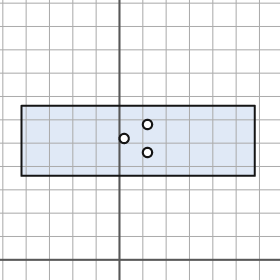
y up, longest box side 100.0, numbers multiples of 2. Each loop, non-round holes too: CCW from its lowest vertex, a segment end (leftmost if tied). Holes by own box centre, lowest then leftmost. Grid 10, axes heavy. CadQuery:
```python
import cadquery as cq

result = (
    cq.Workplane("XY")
    .moveTo(-42.0, 36.0)
    .lineTo(58.0, 36.0)
    .lineTo(58.0, 66.0)
    .lineTo(-42.0, 66.0)
    .close()
    .moveTo(12.0, 46.0)
    .circle(2.0)
    .moveTo(2.0, 52.0)
    .circle(2.0)
    .moveTo(12.0, 58.0)
    .circle(2.0)
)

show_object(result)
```